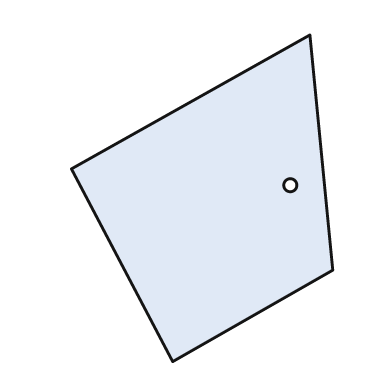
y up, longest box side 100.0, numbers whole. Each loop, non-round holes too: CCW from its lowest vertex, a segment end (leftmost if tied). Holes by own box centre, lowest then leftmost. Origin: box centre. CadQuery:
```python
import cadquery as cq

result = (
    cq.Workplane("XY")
    .moveTo(-9.0, -50.0)
    .lineTo(40.0, -22.0)
    .lineTo(33.0, 50.0)
    .lineTo(-40.0, 9.0)
    .close()
    .moveTo(27.0, 4.0)
    .circle(2.0)
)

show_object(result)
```